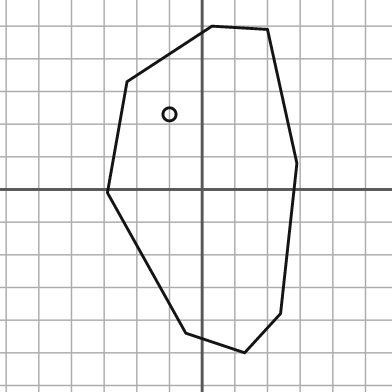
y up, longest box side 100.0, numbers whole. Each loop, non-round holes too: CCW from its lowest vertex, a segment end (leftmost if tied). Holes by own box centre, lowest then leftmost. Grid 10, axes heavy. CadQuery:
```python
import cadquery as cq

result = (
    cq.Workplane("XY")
    .moveTo(13.0, -50.0)
    .lineTo(24.0, -38.0)
    .lineTo(29.0, 8.0)
    .lineTo(20.0, 49.0)
    .lineTo(3.0, 50.0)
    .lineTo(-23.0, 33.0)
    .lineTo(-29.0, -1.0)
    .lineTo(-5.0, -44.0)
    .close()
    .moveTo(-10.0, 23.0)
    .circle(2.0)
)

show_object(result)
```